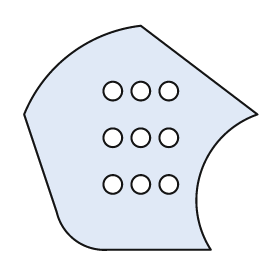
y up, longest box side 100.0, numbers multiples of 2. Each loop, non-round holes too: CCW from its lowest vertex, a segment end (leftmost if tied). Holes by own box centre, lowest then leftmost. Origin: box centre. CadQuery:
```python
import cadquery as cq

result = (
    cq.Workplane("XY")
    .moveTo(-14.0, -48.0)
    .lineTo(30.0, -48.0)
    .threePointArc((26.0, -14.0), (50.0, 10.0))
    .lineTo(0.0, 48.0)
    .threePointArc((-30.0, 36.0), (-50.0, 10.0))
    .lineTo(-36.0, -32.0)
    .threePointArc((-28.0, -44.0), (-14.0, -48.0))
    .close()
    .moveTo(-12.0, -20.0)
    .circle(4.0)
    .moveTo(0.0, -20.0)
    .circle(4.0)
    .moveTo(12.0, -20.0)
    .circle(4.0)
    .moveTo(-12.0, 0.0)
    .circle(4.0)
    .moveTo(0.0, 0.0)
    .circle(4.0)
    .moveTo(12.0, 0.0)
    .circle(4.0)
    .moveTo(-12.0, 20.0)
    .circle(4.0)
    .moveTo(0.0, 20.0)
    .circle(4.0)
    .moveTo(12.0, 20.0)
    .circle(4.0)
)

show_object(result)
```